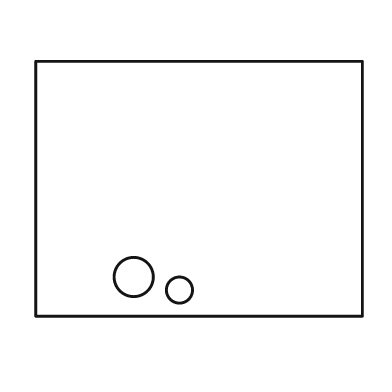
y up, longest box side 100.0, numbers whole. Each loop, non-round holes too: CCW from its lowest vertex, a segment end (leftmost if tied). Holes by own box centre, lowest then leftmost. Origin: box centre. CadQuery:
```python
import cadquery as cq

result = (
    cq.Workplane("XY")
    .moveTo(-50.0, -39.0)
    .lineTo(50.0, -39.0)
    .lineTo(50.0, 39.0)
    .lineTo(-50.0, 39.0)
    .close()
    .moveTo(-6.0, -31.0)
    .circle(4.0)
    .moveTo(-20.0, -27.0)
    .circle(6.0)
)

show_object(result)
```